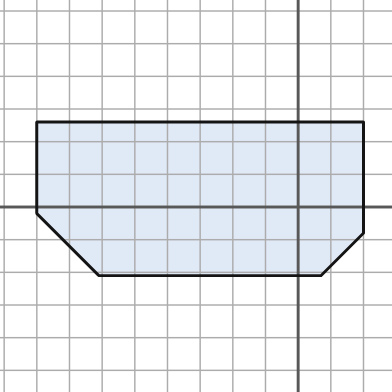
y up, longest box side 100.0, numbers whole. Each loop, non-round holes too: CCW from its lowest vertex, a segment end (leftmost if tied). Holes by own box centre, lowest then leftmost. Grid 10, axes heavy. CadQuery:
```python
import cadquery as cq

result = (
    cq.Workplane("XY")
    .moveTo(-61.0, -21.0)
    .lineTo(7.0, -21.0)
    .lineTo(20.0, -8.0)
    .lineTo(20.0, 26.0)
    .lineTo(-80.0, 26.0)
    .lineTo(-80.0, -2.0)
    .close()
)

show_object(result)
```